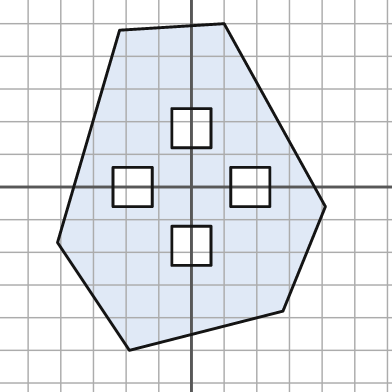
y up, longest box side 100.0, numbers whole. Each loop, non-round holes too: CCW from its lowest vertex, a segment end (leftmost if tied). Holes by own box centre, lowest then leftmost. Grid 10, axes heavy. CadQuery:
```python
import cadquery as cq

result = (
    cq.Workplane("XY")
    .moveTo(-19.0, -50.0)
    .lineTo(28.0, -38.0)
    .lineTo(41.0, -6.0)
    .lineTo(10.0, 50.0)
    .lineTo(-22.0, 48.0)
    .lineTo(-41.0, -17.0)
    .close()
    .moveTo(-6.0, -24.0)
    .lineTo(6.0, -24.0)
    .lineTo(6.0, -12.0)
    .lineTo(-6.0, -12.0)
    .close()
    .moveTo(-24.0, -6.0)
    .lineTo(-12.0, -6.0)
    .lineTo(-12.0, 6.0)
    .lineTo(-24.0, 6.0)
    .close()
    .moveTo(12.0, -6.0)
    .lineTo(24.0, -6.0)
    .lineTo(24.0, 6.0)
    .lineTo(12.0, 6.0)
    .close()
    .moveTo(-6.0, 12.0)
    .lineTo(6.0, 12.0)
    .lineTo(6.0, 24.0)
    .lineTo(-6.0, 24.0)
    .close()
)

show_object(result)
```